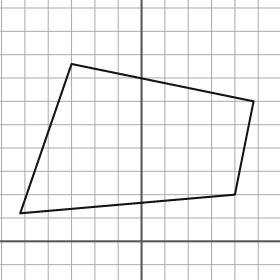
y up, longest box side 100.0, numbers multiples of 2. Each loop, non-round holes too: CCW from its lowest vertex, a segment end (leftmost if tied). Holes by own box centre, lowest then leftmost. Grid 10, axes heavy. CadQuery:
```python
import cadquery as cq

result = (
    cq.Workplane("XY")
    .moveTo(-52.0, 12.0)
    .lineTo(40.0, 20.0)
    .lineTo(48.0, 60.0)
    .lineTo(-30.0, 76.0)
    .close()
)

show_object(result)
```